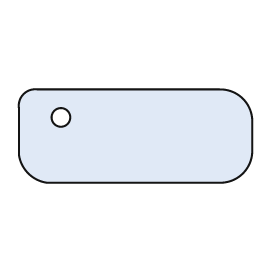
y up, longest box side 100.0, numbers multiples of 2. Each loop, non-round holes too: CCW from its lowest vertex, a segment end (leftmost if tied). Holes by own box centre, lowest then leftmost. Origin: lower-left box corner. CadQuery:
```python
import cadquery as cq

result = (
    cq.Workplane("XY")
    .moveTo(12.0, 0.0)
    .lineTo(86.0, 0.0)
    .threePointArc((96.0, 4.0), (100.0, 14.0))
    .lineTo(100.0, 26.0)
    .threePointArc((96.0, 36.0), (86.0, 40.0))
    .lineTo(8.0, 40.0)
    .threePointArc((2.0, 38.0), (0.0, 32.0))
    .lineTo(0.0, 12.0)
    .threePointArc((4.0, 4.0), (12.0, 0.0))
    .close()
    .moveTo(18.0, 28.0)
    .circle(4.0)
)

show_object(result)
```